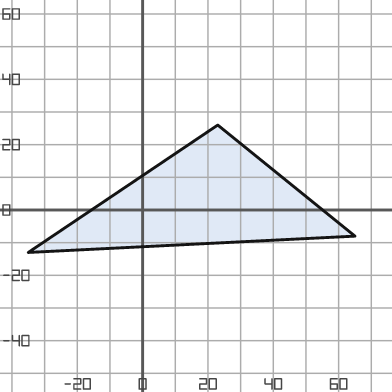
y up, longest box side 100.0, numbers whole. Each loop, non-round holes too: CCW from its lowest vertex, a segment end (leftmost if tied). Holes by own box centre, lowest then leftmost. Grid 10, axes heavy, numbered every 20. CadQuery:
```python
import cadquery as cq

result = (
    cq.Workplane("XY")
    .moveTo(-35.0, -13.0)
    .lineTo(65.0, -8.0)
    .lineTo(23.0, 26.0)
    .close()
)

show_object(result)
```